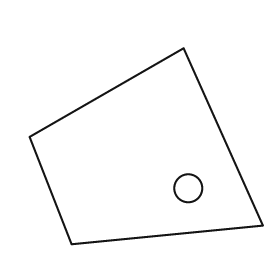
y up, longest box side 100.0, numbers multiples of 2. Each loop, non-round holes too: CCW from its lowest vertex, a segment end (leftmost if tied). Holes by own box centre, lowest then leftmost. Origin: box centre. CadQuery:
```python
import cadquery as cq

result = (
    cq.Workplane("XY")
    .moveTo(-32.0, -42.0)
    .lineTo(50.0, -34.0)
    .lineTo(16.0, 42.0)
    .lineTo(-50.0, 4.0)
    .close()
    .moveTo(18.0, -18.0)
    .circle(6.0)
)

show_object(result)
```